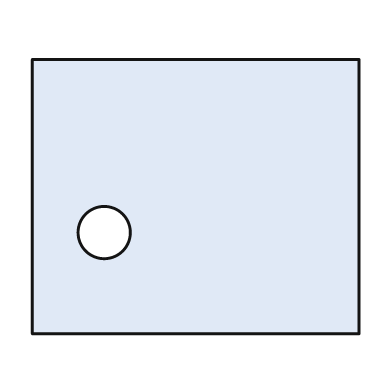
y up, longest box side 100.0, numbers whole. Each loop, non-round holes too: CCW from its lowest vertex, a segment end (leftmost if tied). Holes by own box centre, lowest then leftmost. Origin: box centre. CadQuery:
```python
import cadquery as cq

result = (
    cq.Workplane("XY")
    .moveTo(-50.0, -42.0)
    .lineTo(50.0, -42.0)
    .lineTo(50.0, 42.0)
    .lineTo(-50.0, 42.0)
    .close()
    .moveTo(-28.0, -11.0)
    .circle(8.0)
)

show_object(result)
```